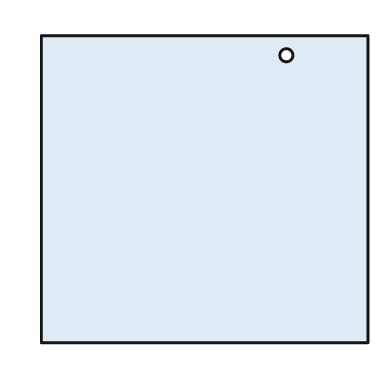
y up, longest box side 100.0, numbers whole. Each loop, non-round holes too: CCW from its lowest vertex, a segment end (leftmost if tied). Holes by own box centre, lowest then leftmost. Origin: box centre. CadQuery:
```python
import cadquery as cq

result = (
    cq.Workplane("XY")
    .moveTo(-50.0, -47.0)
    .lineTo(50.0, -47.0)
    .lineTo(50.0, 47.0)
    .lineTo(-50.0, 47.0)
    .close()
    .moveTo(25.0, 41.0)
    .circle(2.0)
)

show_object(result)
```